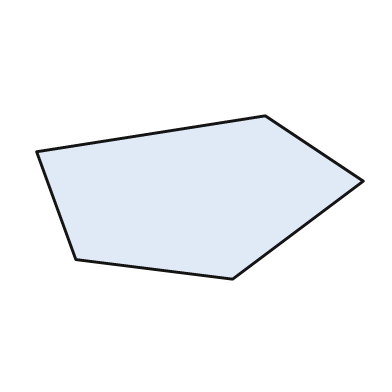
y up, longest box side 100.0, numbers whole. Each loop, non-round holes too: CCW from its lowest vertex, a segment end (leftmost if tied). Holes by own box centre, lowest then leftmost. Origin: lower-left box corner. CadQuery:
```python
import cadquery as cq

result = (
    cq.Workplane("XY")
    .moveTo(60.0, 0.0)
    .lineTo(100.0, 30.0)
    .lineTo(70.0, 50.0)
    .lineTo(0.0, 39.0)
    .lineTo(12.0, 6.0)
    .close()
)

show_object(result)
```